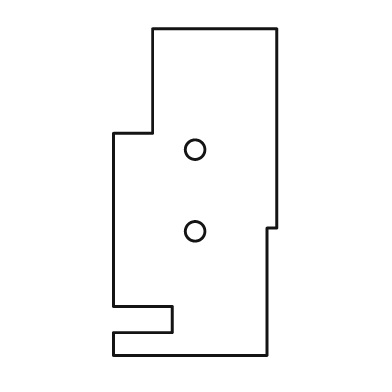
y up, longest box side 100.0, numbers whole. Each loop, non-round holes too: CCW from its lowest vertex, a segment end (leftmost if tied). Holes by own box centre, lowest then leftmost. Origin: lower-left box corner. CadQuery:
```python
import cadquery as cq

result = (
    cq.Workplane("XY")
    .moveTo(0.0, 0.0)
    .lineTo(47.0, 0.0)
    .lineTo(47.0, 39.0)
    .lineTo(50.0, 39.0)
    .lineTo(50.0, 100.0)
    .lineTo(12.0, 100.0)
    .lineTo(12.0, 68.0)
    .lineTo(0.0, 68.0)
    .lineTo(0.0, 15.0)
    .lineTo(18.0, 15.0)
    .lineTo(18.0, 7.0)
    .lineTo(0.0, 7.0)
    .close()
    .moveTo(25.0, 38.0)
    .circle(3.0)
    .moveTo(25.0, 63.0)
    .circle(3.0)
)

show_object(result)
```